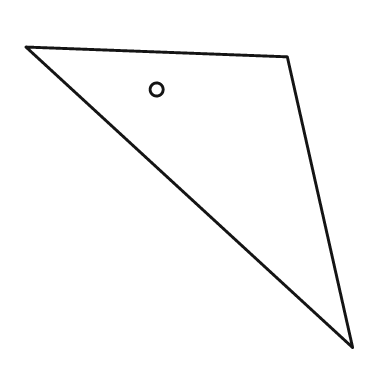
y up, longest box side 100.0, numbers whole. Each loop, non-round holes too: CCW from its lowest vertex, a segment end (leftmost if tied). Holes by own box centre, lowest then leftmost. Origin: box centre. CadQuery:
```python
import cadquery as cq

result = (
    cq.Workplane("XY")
    .moveTo(50.0, -46.0)
    .lineTo(30.0, 43.0)
    .lineTo(-50.0, 46.0)
    .close()
    .moveTo(-10.0, 33.0)
    .circle(2.0)
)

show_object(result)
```